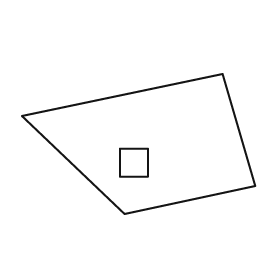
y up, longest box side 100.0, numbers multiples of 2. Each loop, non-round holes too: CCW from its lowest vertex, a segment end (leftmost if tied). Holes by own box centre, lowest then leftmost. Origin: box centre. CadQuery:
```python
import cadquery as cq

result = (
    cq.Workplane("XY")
    .moveTo(-6.0, -30.0)
    .lineTo(50.0, -18.0)
    .lineTo(36.0, 30.0)
    .lineTo(-50.0, 12.0)
    .close()
    .moveTo(-8.0, -14.0)
    .lineTo(4.0, -14.0)
    .lineTo(4.0, -2.0)
    .lineTo(-8.0, -2.0)
    .close()
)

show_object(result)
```